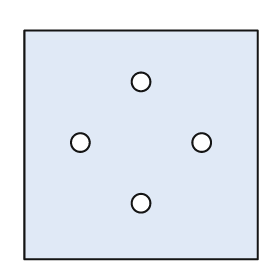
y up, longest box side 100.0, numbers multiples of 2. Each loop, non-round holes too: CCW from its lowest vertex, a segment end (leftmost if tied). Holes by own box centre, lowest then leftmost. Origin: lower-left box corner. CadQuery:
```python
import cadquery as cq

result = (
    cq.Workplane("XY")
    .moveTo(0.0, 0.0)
    .lineTo(100.0, 0.0)
    .lineTo(100.0, 98.0)
    .lineTo(0.0, 98.0)
    .close()
    .moveTo(50.0, 24.0)
    .circle(4.0)
    .moveTo(24.0, 50.0)
    .circle(4.0)
    .moveTo(76.0, 50.0)
    .circle(4.0)
    .moveTo(50.0, 76.0)
    .circle(4.0)
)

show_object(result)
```